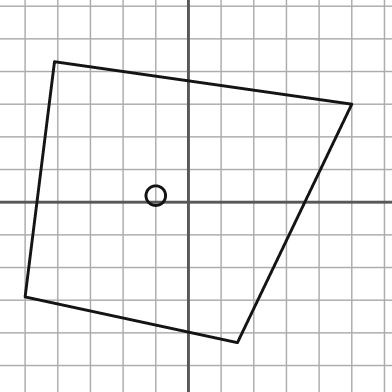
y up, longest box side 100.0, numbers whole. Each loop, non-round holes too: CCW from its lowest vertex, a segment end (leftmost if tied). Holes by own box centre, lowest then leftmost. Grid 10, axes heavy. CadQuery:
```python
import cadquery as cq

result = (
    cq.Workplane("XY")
    .moveTo(15.0, -43.0)
    .lineTo(50.0, 30.0)
    .lineTo(-41.0, 43.0)
    .lineTo(-50.0, -29.0)
    .close()
    .moveTo(-10.0, 2.0)
    .circle(3.0)
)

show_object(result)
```